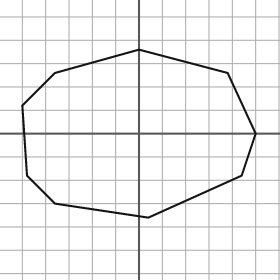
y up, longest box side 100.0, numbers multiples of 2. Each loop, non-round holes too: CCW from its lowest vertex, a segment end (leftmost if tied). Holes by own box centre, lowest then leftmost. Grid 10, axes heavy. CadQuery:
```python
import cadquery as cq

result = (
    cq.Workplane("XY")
    .moveTo(4.0, -36.0)
    .lineTo(44.0, -18.0)
    .lineTo(50.0, 0.0)
    .lineTo(38.0, 26.0)
    .lineTo(0.0, 36.0)
    .lineTo(-36.0, 26.0)
    .lineTo(-50.0, 12.0)
    .lineTo(-48.0, -18.0)
    .lineTo(-36.0, -30.0)
    .close()
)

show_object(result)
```